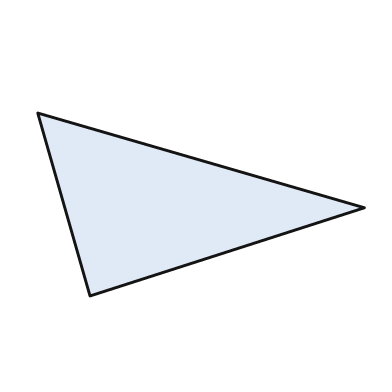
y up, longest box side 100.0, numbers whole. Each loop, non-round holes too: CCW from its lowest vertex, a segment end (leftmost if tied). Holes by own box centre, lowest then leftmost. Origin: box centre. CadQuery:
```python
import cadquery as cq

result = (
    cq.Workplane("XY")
    .moveTo(-34.0, -28.0)
    .lineTo(50.0, -1.0)
    .lineTo(-50.0, 28.0)
    .close()
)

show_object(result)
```